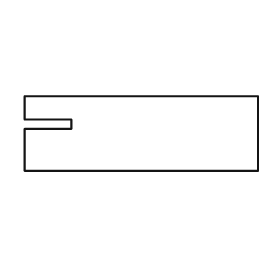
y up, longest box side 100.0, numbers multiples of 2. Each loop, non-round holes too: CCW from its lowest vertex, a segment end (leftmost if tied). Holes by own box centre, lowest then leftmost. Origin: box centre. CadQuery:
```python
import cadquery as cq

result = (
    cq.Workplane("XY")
    .moveTo(-50.0, -16.0)
    .lineTo(50.0, -16.0)
    .lineTo(50.0, 16.0)
    .lineTo(-50.0, 16.0)
    .lineTo(-50.0, 6.0)
    .lineTo(-30.0, 6.0)
    .lineTo(-30.0, 2.0)
    .lineTo(-50.0, 2.0)
    .close()
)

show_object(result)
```